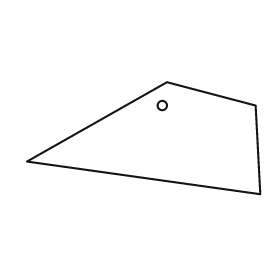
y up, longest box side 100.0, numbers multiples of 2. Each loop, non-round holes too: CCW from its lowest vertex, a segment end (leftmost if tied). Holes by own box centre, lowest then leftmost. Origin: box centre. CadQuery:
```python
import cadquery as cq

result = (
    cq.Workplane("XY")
    .moveTo(50.0, -24.0)
    .lineTo(48.0, 14.0)
    .lineTo(10.0, 24.0)
    .lineTo(-50.0, -10.0)
    .close()
    .moveTo(8.0, 14.0)
    .circle(2.0)
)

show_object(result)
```